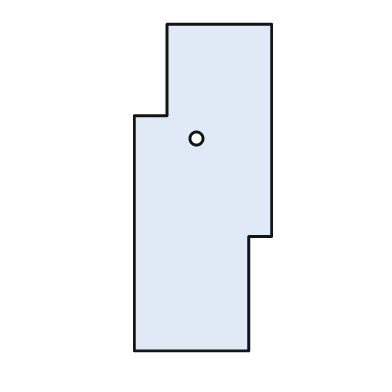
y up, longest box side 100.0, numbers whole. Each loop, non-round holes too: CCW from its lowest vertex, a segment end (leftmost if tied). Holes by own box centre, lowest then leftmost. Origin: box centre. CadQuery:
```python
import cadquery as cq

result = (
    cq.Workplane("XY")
    .moveTo(-21.0, -50.0)
    .lineTo(14.0, -50.0)
    .lineTo(14.0, -15.0)
    .lineTo(21.0, -15.0)
    .lineTo(21.0, 50.0)
    .lineTo(-11.0, 50.0)
    .lineTo(-11.0, 22.0)
    .lineTo(-21.0, 22.0)
    .close()
    .moveTo(-2.0, 15.0)
    .circle(2.0)
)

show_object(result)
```